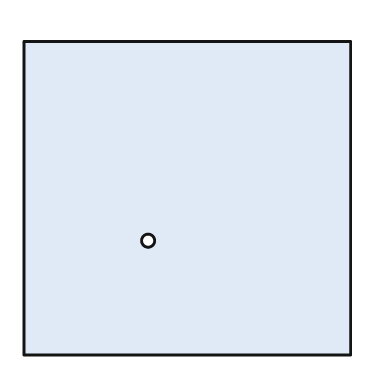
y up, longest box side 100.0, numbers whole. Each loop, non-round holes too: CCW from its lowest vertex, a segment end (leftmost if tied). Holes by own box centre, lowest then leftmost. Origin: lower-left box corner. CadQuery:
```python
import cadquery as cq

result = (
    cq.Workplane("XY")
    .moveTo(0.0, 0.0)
    .lineTo(100.0, 0.0)
    .lineTo(100.0, 96.0)
    .lineTo(0.0, 96.0)
    .close()
    .moveTo(38.0, 35.0)
    .circle(2.0)
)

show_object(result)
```